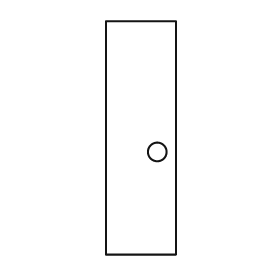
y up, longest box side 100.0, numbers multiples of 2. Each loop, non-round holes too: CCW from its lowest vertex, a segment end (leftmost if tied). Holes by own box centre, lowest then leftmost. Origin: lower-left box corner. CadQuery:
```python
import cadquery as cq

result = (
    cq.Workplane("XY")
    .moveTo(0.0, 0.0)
    .lineTo(30.0, 0.0)
    .lineTo(30.0, 100.0)
    .lineTo(0.0, 100.0)
    .close()
    .moveTo(22.0, 44.0)
    .circle(4.0)
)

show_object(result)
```